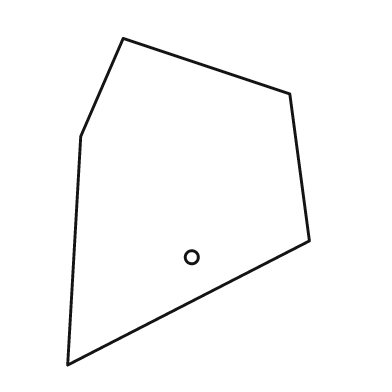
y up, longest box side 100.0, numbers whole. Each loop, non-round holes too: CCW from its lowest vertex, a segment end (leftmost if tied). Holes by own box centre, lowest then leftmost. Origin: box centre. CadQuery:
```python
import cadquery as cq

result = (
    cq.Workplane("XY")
    .moveTo(-37.0, -50.0)
    .lineTo(37.0, -12.0)
    .lineTo(31.0, 33.0)
    .lineTo(-20.0, 50.0)
    .lineTo(-33.0, 20.0)
    .close()
    .moveTo(1.0, -17.0)
    .circle(2.0)
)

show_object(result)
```